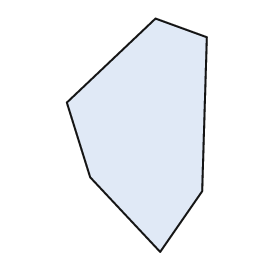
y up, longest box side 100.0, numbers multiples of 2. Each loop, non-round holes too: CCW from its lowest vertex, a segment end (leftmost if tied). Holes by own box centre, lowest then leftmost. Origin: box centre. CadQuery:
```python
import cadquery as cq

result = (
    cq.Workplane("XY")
    .moveTo(10.0, -50.0)
    .lineTo(28.0, -24.0)
    .lineTo(30.0, 42.0)
    .lineTo(8.0, 50.0)
    .lineTo(-30.0, 14.0)
    .lineTo(-20.0, -18.0)
    .close()
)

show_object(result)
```